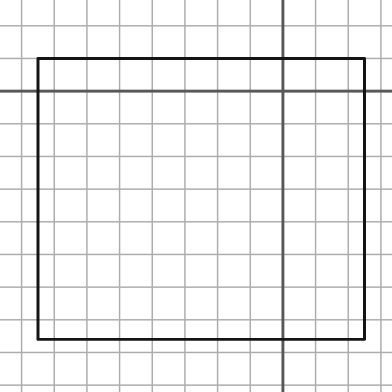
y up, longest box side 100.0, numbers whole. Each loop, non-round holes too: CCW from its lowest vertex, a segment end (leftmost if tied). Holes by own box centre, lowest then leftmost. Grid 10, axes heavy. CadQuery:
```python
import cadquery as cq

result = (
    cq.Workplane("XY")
    .moveTo(-75.0, -76.0)
    .lineTo(25.0, -76.0)
    .lineTo(25.0, 10.0)
    .lineTo(-75.0, 10.0)
    .close()
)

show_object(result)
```